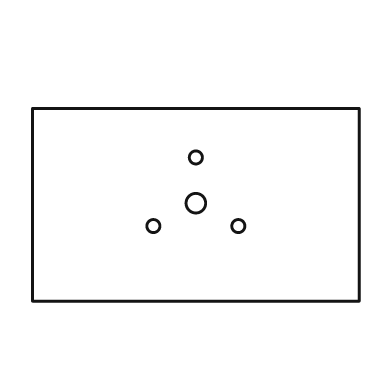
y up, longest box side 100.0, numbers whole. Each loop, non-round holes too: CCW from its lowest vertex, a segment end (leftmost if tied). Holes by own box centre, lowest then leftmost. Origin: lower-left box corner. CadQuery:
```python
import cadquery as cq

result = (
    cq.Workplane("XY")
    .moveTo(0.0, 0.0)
    .lineTo(100.0, 0.0)
    .lineTo(100.0, 59.0)
    .lineTo(0.0, 59.0)
    .close()
    .moveTo(37.0, 23.0)
    .circle(2.0)
    .moveTo(63.0, 23.0)
    .circle(2.0)
    .moveTo(50.0, 30.0)
    .circle(3.0)
    .moveTo(50.0, 44.0)
    .circle(2.0)
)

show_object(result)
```